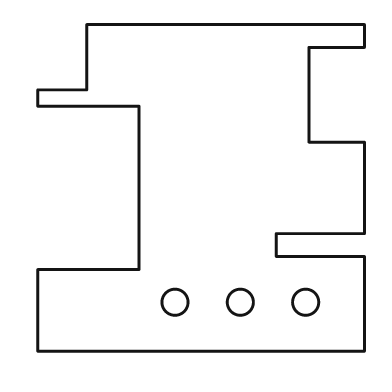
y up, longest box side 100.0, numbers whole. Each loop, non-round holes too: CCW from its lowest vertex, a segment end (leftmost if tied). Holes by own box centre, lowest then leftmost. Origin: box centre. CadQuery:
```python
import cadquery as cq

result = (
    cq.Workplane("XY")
    .moveTo(-50.0, -50.0)
    .lineTo(50.0, -50.0)
    .lineTo(50.0, -21.0)
    .lineTo(23.0, -21.0)
    .lineTo(23.0, -14.0)
    .lineTo(50.0, -14.0)
    .lineTo(50.0, 14.0)
    .lineTo(33.0, 14.0)
    .lineTo(33.0, 43.0)
    .lineTo(50.0, 43.0)
    .lineTo(50.0, 50.0)
    .lineTo(-35.0, 50.0)
    .lineTo(-35.0, 30.0)
    .lineTo(-50.0, 30.0)
    .lineTo(-50.0, 25.0)
    .lineTo(-19.0, 25.0)
    .lineTo(-19.0, -25.0)
    .lineTo(-50.0, -25.0)
    .close()
    .moveTo(-8.0, -35.0)
    .circle(4.0)
    .moveTo(12.0, -35.0)
    .circle(4.0)
    .moveTo(32.0, -35.0)
    .circle(4.0)
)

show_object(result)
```